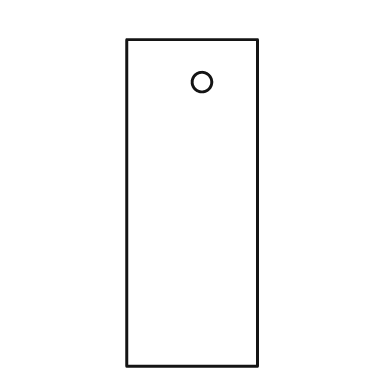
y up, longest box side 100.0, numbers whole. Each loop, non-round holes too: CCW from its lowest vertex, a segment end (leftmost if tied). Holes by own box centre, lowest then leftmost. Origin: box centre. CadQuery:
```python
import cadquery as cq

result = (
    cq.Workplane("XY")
    .moveTo(-20.0, -50.0)
    .lineTo(20.0, -50.0)
    .lineTo(20.0, 50.0)
    .lineTo(-20.0, 50.0)
    .close()
    .moveTo(3.0, 37.0)
    .circle(3.0)
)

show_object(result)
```